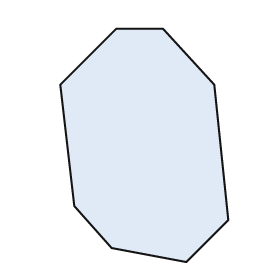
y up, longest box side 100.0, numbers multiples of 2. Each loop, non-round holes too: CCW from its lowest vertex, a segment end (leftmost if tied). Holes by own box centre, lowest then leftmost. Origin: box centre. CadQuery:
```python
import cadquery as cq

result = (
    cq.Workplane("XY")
    .moveTo(18.0, -50.0)
    .lineTo(36.0, -32.0)
    .lineTo(30.0, 26.0)
    .lineTo(8.0, 50.0)
    .lineTo(-12.0, 50.0)
    .lineTo(-36.0, 26.0)
    .lineTo(-30.0, -26.0)
    .lineTo(-14.0, -44.0)
    .close()
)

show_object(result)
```